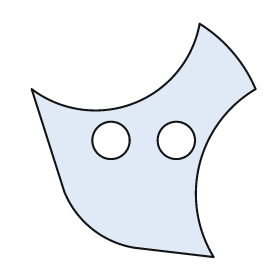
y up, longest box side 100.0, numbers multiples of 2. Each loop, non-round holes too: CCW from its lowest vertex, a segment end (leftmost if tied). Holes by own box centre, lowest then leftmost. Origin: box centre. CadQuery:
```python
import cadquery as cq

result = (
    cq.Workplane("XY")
    .moveTo(30.0, -50.0)
    .threePointArc((24.0, -10.0), (48.0, 22.0))
    .threePointArc((38.0, 38.0), (24.0, 50.0))
    .threePointArc((-4.0, 16.0), (-48.0, 22.0))
    .lineTo(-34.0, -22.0)
    .threePointArc((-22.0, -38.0), (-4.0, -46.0))
    .close()
    .moveTo(-14.0, 0.0)
    .circle(8.0)
    .moveTo(14.0, 0.0)
    .circle(8.0)
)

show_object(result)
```